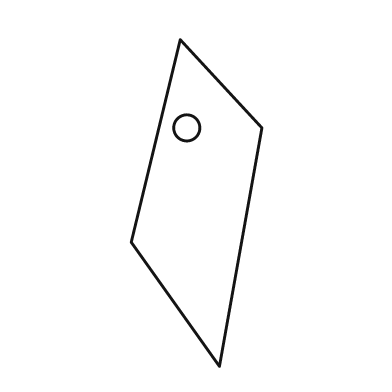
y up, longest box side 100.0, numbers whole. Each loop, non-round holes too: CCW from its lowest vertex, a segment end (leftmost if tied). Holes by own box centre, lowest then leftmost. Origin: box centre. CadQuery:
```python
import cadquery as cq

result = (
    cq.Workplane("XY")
    .moveTo(7.0, -50.0)
    .lineTo(20.0, 23.0)
    .lineTo(-5.0, 50.0)
    .lineTo(-20.0, -12.0)
    .close()
    .moveTo(-3.0, 23.0)
    .circle(4.0)
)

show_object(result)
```